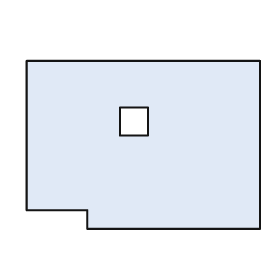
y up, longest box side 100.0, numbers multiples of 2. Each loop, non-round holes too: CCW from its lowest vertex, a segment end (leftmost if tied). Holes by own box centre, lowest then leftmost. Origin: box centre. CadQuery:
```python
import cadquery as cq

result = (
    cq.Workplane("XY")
    .moveTo(-24.0, -36.0)
    .lineTo(50.0, -36.0)
    .lineTo(50.0, 36.0)
    .lineTo(-50.0, 36.0)
    .lineTo(-50.0, -28.0)
    .lineTo(-24.0, -28.0)
    .close()
    .moveTo(-10.0, 4.0)
    .lineTo(2.0, 4.0)
    .lineTo(2.0, 16.0)
    .lineTo(-10.0, 16.0)
    .close()
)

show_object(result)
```